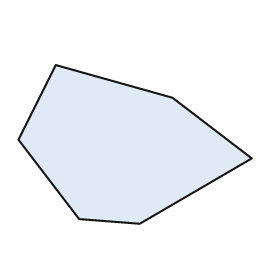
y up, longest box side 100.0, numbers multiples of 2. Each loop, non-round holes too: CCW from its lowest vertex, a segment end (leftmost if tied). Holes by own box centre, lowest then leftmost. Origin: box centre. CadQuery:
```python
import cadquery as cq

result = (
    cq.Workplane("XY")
    .moveTo(2.0, -34.0)
    .lineTo(50.0, -6.0)
    .lineTo(16.0, 20.0)
    .lineTo(-34.0, 34.0)
    .lineTo(-50.0, 2.0)
    .lineTo(-24.0, -32.0)
    .close()
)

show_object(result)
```